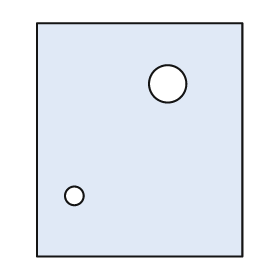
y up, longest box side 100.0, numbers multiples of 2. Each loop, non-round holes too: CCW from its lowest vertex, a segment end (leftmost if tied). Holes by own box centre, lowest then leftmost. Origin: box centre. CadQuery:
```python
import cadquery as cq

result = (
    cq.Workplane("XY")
    .moveTo(-44.0, -50.0)
    .lineTo(44.0, -50.0)
    .lineTo(44.0, 50.0)
    .lineTo(-44.0, 50.0)
    .close()
    .moveTo(-28.0, -24.0)
    .circle(4.0)
    .moveTo(12.0, 24.0)
    .circle(8.0)
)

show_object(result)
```